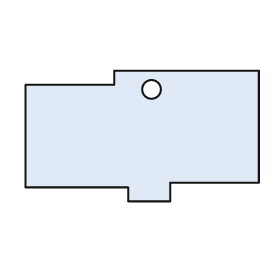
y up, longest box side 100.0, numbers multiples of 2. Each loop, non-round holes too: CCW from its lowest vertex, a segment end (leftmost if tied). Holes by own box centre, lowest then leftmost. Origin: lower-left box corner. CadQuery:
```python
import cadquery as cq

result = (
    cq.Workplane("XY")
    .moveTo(44.0, 0.0)
    .lineTo(62.0, 0.0)
    .lineTo(62.0, 8.0)
    .lineTo(100.0, 8.0)
    .lineTo(100.0, 56.0)
    .lineTo(38.0, 56.0)
    .lineTo(38.0, 50.0)
    .lineTo(0.0, 50.0)
    .lineTo(0.0, 6.0)
    .lineTo(44.0, 6.0)
    .close()
    .moveTo(54.0, 48.0)
    .circle(4.0)
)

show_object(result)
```